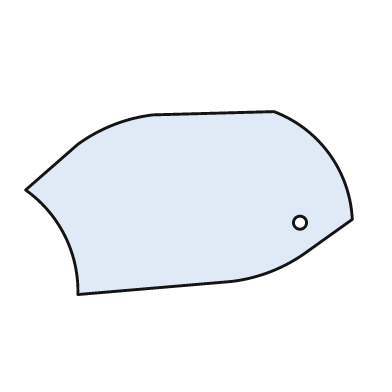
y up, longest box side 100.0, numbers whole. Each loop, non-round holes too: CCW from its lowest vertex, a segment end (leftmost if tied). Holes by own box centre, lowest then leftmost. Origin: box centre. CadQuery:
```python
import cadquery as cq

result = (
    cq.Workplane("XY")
    .moveTo(-34.0, -28.0)
    .lineTo(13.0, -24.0)
    .threePointArc((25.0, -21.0), (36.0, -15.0))
    .lineTo(50.0, -5.0)
    .threePointArc((43.0, 15.0), (26.0, 28.0))
    .lineTo(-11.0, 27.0)
    .threePointArc((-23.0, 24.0), (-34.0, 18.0))
    .lineTo(-50.0, 4.0)
    .threePointArc((-38.0, -10.0), (-34.0, -28.0))
    .close()
    .moveTo(34.0, -6.0)
    .circle(2.0)
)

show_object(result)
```